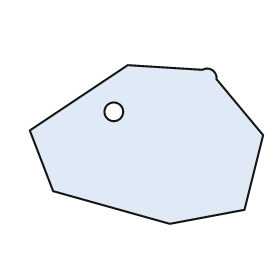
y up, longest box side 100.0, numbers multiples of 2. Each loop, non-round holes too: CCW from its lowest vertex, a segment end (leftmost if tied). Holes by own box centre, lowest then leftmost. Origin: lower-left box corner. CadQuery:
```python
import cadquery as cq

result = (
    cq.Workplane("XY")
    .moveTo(60.0, 0.0)
    .lineTo(92.0, 6.0)
    .lineTo(100.0, 38.0)
    .lineTo(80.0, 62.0)
    .threePointArc((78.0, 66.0), (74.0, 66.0))
    .lineTo(42.0, 68.0)
    .lineTo(0.0, 40.0)
    .lineTo(10.0, 14.0)
    .close()
    .moveTo(36.0, 48.0)
    .circle(4.0)
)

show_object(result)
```